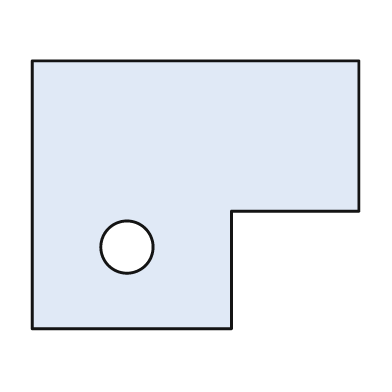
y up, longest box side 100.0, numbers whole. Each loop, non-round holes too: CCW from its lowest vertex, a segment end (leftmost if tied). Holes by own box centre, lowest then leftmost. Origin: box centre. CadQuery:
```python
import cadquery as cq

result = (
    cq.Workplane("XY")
    .moveTo(-50.0, -41.0)
    .lineTo(11.0, -41.0)
    .lineTo(11.0, -5.0)
    .lineTo(50.0, -5.0)
    .lineTo(50.0, 41.0)
    .lineTo(-50.0, 41.0)
    .close()
    .moveTo(-21.0, -16.0)
    .circle(8.0)
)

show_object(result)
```